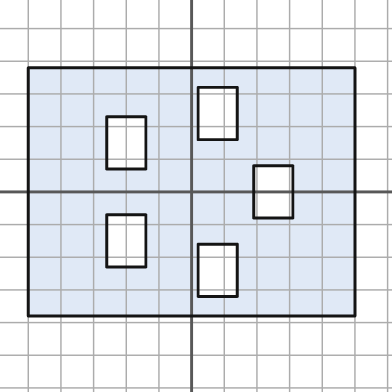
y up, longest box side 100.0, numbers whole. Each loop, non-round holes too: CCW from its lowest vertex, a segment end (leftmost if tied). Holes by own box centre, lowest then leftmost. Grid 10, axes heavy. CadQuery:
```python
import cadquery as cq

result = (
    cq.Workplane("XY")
    .moveTo(-50.0, -38.0)
    .lineTo(50.0, -38.0)
    .lineTo(50.0, 38.0)
    .lineTo(-50.0, 38.0)
    .close()
    .moveTo(2.0, -32.0)
    .lineTo(14.0, -32.0)
    .lineTo(14.0, -16.0)
    .lineTo(2.0, -16.0)
    .close()
    .moveTo(-26.0, -23.0)
    .lineTo(-14.0, -23.0)
    .lineTo(-14.0, -7.0)
    .lineTo(-26.0, -7.0)
    .close()
    .moveTo(19.0, -8.0)
    .lineTo(31.0, -8.0)
    .lineTo(31.0, 8.0)
    .lineTo(19.0, 8.0)
    .close()
    .moveTo(-26.0, 7.0)
    .lineTo(-14.0, 7.0)
    .lineTo(-14.0, 23.0)
    .lineTo(-26.0, 23.0)
    .close()
    .moveTo(2.0, 16.0)
    .lineTo(14.0, 16.0)
    .lineTo(14.0, 32.0)
    .lineTo(2.0, 32.0)
    .close()
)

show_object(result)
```